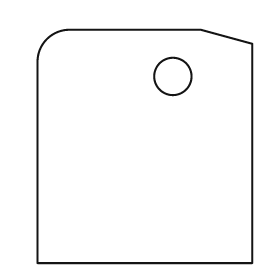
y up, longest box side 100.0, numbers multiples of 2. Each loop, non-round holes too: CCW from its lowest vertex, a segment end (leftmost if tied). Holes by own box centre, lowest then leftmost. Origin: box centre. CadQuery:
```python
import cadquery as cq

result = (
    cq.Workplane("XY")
    .moveTo(-46.0, -50.0)
    .lineTo(46.0, -50.0)
    .lineTo(46.0, 44.0)
    .lineTo(24.0, 50.0)
    .lineTo(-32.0, 50.0)
    .threePointArc((-42.0, 46.0), (-46.0, 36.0))
    .close()
    .moveTo(12.0, 30.0)
    .circle(8.0)
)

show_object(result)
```